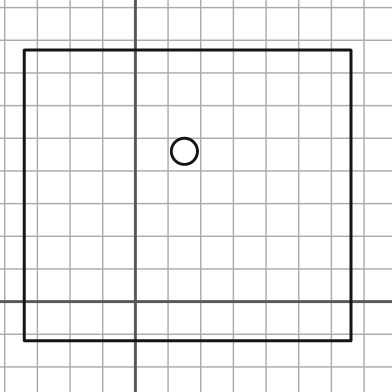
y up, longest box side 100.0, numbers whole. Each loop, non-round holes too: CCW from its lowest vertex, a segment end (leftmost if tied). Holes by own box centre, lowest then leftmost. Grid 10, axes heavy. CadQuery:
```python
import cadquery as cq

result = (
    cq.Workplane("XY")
    .moveTo(-34.0, -12.0)
    .lineTo(66.0, -12.0)
    .lineTo(66.0, 77.0)
    .lineTo(-34.0, 77.0)
    .close()
    .moveTo(15.0, 46.0)
    .circle(4.0)
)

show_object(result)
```